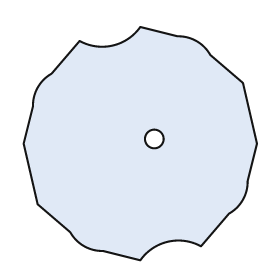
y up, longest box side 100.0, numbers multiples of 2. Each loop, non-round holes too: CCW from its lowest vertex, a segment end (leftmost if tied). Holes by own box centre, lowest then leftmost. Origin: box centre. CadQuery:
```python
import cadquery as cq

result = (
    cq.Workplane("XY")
    .moveTo(0.0, -50.0)
    .threePointArc((12.0, -42.0), (26.0, -44.0))
    .lineTo(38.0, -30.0)
    .threePointArc((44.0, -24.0), (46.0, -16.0))
    .lineTo(50.0, 0.0)
    .lineTo(44.0, 26.0)
    .lineTo(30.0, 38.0)
    .threePointArc((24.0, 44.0), (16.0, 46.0))
    .lineTo(0.0, 50.0)
    .threePointArc((-12.0, 42.0), (-26.0, 44.0))
    .lineTo(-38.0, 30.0)
    .threePointArc((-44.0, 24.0), (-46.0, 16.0))
    .lineTo(-50.0, 0.0)
    .lineTo(-44.0, -26.0)
    .lineTo(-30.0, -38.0)
    .threePointArc((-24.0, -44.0), (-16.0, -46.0))
    .close()
    .moveTo(6.0, 2.0)
    .circle(4.0)
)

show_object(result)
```